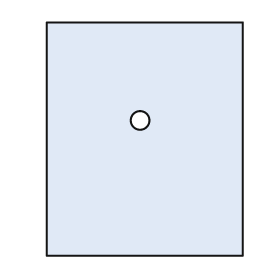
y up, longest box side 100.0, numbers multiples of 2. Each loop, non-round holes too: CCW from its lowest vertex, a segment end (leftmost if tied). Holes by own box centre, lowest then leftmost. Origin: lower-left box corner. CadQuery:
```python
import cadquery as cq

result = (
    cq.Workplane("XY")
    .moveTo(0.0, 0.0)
    .lineTo(84.0, 0.0)
    .lineTo(84.0, 100.0)
    .lineTo(0.0, 100.0)
    .close()
    .moveTo(40.0, 58.0)
    .circle(4.0)
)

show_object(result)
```